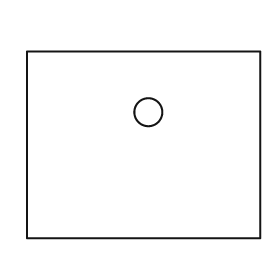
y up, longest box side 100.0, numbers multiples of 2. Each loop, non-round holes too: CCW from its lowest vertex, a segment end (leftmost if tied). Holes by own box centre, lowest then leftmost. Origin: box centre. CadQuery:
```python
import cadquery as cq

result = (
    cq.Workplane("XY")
    .moveTo(-50.0, -40.0)
    .lineTo(50.0, -40.0)
    .lineTo(50.0, 40.0)
    .lineTo(-50.0, 40.0)
    .close()
    .moveTo(2.0, 14.0)
    .circle(6.0)
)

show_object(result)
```